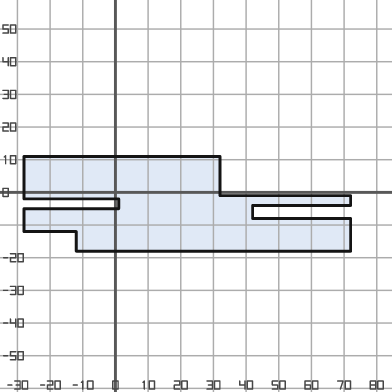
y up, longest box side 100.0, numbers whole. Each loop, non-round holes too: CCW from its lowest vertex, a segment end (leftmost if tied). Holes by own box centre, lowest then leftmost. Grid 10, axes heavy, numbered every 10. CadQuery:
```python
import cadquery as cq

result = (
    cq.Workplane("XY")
    .moveTo(-12.0, -18.0)
    .lineTo(72.0, -18.0)
    .lineTo(72.0, -8.0)
    .lineTo(42.0, -8.0)
    .lineTo(42.0, -4.0)
    .lineTo(72.0, -4.0)
    .lineTo(72.0, -1.0)
    .lineTo(32.0, -1.0)
    .lineTo(32.0, 11.0)
    .lineTo(-28.0, 11.0)
    .lineTo(-28.0, -2.0)
    .lineTo(1.0, -2.0)
    .lineTo(1.0, -5.0)
    .lineTo(-28.0, -5.0)
    .lineTo(-28.0, -12.0)
    .lineTo(-12.0, -12.0)
    .close()
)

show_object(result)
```